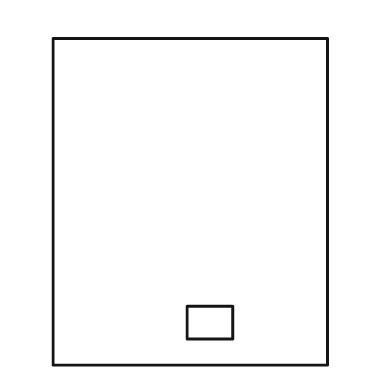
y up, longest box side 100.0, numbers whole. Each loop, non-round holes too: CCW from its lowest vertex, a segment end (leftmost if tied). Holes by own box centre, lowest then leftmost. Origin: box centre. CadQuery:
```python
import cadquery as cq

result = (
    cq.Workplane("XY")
    .moveTo(-42.0, -50.0)
    .lineTo(42.0, -50.0)
    .lineTo(42.0, 50.0)
    .lineTo(-42.0, 50.0)
    .close()
    .moveTo(-1.0, -42.0)
    .lineTo(13.0, -42.0)
    .lineTo(13.0, -32.0)
    .lineTo(-1.0, -32.0)
    .close()
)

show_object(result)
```